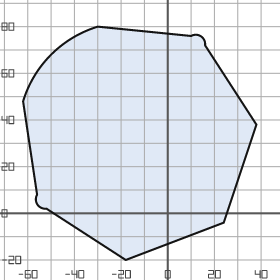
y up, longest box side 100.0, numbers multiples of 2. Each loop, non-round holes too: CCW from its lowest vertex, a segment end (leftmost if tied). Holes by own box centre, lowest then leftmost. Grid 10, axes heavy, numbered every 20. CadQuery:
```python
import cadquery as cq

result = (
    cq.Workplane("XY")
    .moveTo(-18.0, -20.0)
    .lineTo(24.0, -4.0)
    .lineTo(38.0, 38.0)
    .lineTo(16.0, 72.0)
    .threePointArc((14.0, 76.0), (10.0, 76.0))
    .lineTo(-30.0, 80.0)
    .threePointArc((-50.0, 68.0), (-62.0, 48.0))
    .lineTo(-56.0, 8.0)
    .threePointArc((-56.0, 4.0), (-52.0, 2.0))
    .close()
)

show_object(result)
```